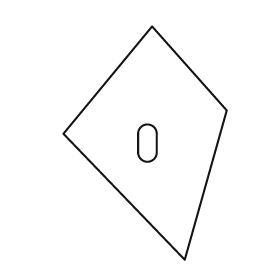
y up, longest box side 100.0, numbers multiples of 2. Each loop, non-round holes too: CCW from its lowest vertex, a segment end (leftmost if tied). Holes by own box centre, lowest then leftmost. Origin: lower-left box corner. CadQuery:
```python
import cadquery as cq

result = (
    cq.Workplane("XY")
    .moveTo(52.0, 0.0)
    .lineTo(70.0, 64.0)
    .lineTo(38.0, 100.0)
    .lineTo(0.0, 54.0)
    .close()
    .moveTo(32.0, 46.0)
    .threePointArc((36.0, 42.0), (40.0, 46.0))
    .lineTo(40.0, 54.0)
    .threePointArc((36.0, 58.0), (32.0, 54.0))
    .close()
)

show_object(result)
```